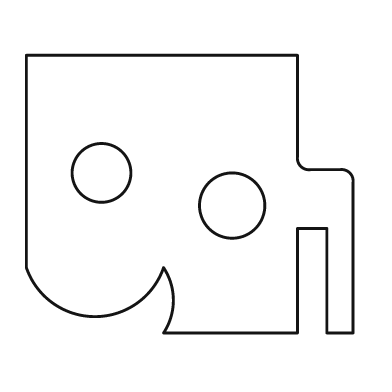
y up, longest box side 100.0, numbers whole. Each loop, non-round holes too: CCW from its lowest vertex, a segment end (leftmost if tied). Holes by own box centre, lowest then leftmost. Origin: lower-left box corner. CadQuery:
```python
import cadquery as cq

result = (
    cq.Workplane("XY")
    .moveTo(42.0, 0.0)
    .lineTo(83.0, 0.0)
    .lineTo(83.0, 32.0)
    .lineTo(92.0, 32.0)
    .lineTo(92.0, 0.0)
    .lineTo(100.0, 0.0)
    .lineTo(100.0, 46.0)
    .threePointArc((99.0, 49.0), (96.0, 50.0))
    .lineTo(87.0, 50.0)
    .threePointArc((84.0, 51.0), (83.0, 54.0))
    .lineTo(83.0, 85.0)
    .lineTo(0.0, 85.0)
    .lineTo(0.0, 20.0)
    .threePointArc((21.0, 5.0), (42.0, 20.0))
    .threePointArc((45.0, 10.0), (42.0, 0.0))
    .close()
    .moveTo(63.0, 39.0)
    .circle(10.0)
    .moveTo(23.0, 49.0)
    .circle(9.0)
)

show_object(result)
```